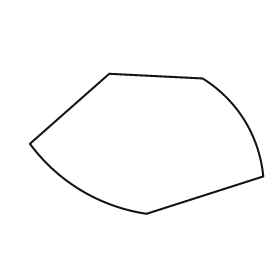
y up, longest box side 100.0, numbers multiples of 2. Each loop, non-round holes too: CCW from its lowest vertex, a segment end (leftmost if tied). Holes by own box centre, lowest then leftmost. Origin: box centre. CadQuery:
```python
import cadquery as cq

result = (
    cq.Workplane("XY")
    .moveTo(0.0, -30.0)
    .lineTo(50.0, -14.0)
    .threePointArc((42.0, 10.0), (24.0, 28.0))
    .lineTo(-16.0, 30.0)
    .lineTo(-50.0, 0.0)
    .threePointArc((-28.0, -20.0), (0.0, -30.0))
    .close()
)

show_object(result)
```